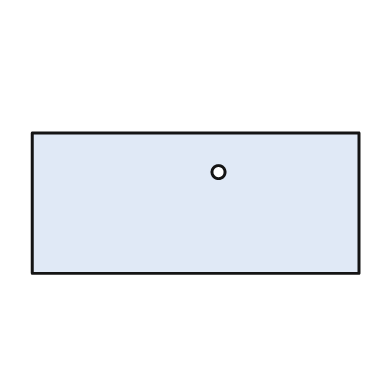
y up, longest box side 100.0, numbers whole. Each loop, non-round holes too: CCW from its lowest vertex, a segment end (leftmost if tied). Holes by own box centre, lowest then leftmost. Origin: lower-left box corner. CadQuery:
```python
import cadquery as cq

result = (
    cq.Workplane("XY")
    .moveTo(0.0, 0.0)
    .lineTo(100.0, 0.0)
    .lineTo(100.0, 43.0)
    .lineTo(0.0, 43.0)
    .close()
    .moveTo(57.0, 31.0)
    .circle(2.0)
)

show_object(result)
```